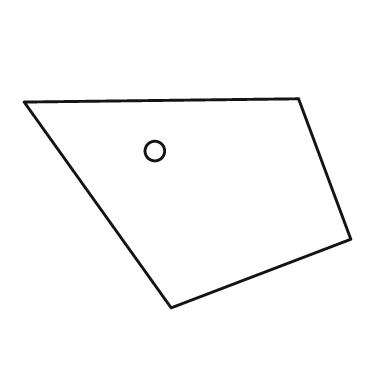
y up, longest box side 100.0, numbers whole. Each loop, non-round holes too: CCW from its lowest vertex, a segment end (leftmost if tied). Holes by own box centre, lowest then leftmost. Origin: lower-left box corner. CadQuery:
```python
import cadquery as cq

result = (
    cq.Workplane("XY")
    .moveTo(45.0, 0.0)
    .lineTo(100.0, 21.0)
    .lineTo(84.0, 64.0)
    .lineTo(0.0, 63.0)
    .close()
    .moveTo(40.0, 48.0)
    .circle(3.0)
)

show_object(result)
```